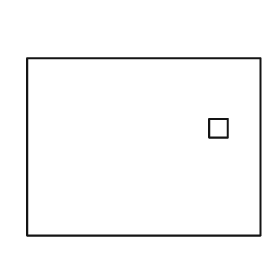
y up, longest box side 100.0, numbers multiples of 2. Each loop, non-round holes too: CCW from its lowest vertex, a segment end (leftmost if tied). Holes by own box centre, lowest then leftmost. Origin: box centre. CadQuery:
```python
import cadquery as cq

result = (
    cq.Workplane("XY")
    .moveTo(-50.0, -38.0)
    .lineTo(50.0, -38.0)
    .lineTo(50.0, 38.0)
    .lineTo(-50.0, 38.0)
    .close()
    .moveTo(28.0, 4.0)
    .lineTo(36.0, 4.0)
    .lineTo(36.0, 12.0)
    .lineTo(28.0, 12.0)
    .close()
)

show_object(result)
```